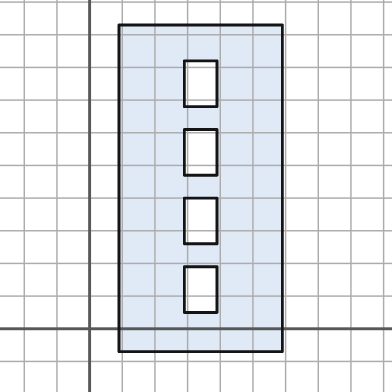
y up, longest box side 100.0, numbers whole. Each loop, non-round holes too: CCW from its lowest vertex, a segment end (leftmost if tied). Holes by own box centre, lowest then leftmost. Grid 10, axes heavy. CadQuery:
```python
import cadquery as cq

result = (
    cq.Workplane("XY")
    .moveTo(9.0, -7.0)
    .lineTo(59.0, -7.0)
    .lineTo(59.0, 93.0)
    .lineTo(9.0, 93.0)
    .close()
    .moveTo(29.0, 5.0)
    .lineTo(39.0, 5.0)
    .lineTo(39.0, 19.0)
    .lineTo(29.0, 19.0)
    .close()
    .moveTo(29.0, 26.0)
    .lineTo(39.0, 26.0)
    .lineTo(39.0, 40.0)
    .lineTo(29.0, 40.0)
    .close()
    .moveTo(29.0, 47.0)
    .lineTo(39.0, 47.0)
    .lineTo(39.0, 61.0)
    .lineTo(29.0, 61.0)
    .close()
    .moveTo(29.0, 68.0)
    .lineTo(39.0, 68.0)
    .lineTo(39.0, 82.0)
    .lineTo(29.0, 82.0)
    .close()
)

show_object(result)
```